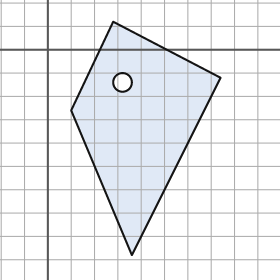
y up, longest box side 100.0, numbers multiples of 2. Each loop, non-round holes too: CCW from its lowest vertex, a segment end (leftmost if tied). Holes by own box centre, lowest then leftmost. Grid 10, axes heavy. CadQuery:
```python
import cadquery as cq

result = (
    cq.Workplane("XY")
    .moveTo(36.0, -88.0)
    .lineTo(74.0, -12.0)
    .lineTo(28.0, 12.0)
    .lineTo(10.0, -26.0)
    .close()
    .moveTo(32.0, -14.0)
    .circle(4.0)
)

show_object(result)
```